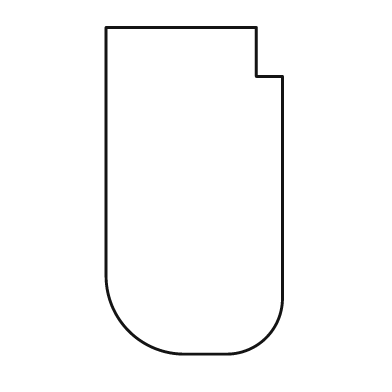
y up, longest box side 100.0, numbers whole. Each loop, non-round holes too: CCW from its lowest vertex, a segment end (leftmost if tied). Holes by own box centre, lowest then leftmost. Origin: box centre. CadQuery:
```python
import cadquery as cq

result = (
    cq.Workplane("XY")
    .moveTo(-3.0, -50.0)
    .lineTo(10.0, -50.0)
    .threePointArc((22.0, -45.0), (27.0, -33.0))
    .lineTo(27.0, 35.0)
    .lineTo(19.0, 35.0)
    .lineTo(19.0, 50.0)
    .lineTo(-27.0, 50.0)
    .lineTo(-27.0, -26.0)
    .threePointArc((-20.0, -43.0), (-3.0, -50.0))
    .close()
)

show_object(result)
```